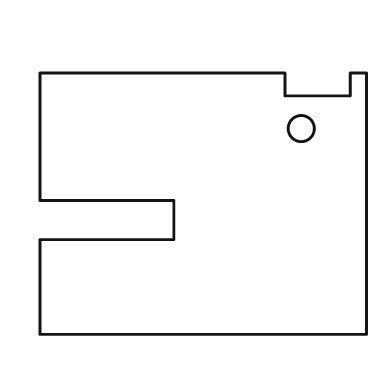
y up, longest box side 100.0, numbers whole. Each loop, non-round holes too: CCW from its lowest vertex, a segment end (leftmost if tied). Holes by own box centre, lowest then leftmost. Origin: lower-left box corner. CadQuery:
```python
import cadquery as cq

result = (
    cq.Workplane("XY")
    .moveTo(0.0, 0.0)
    .lineTo(100.0, 0.0)
    .lineTo(100.0, 80.0)
    .lineTo(95.0, 80.0)
    .lineTo(95.0, 73.0)
    .lineTo(75.0, 73.0)
    .lineTo(75.0, 80.0)
    .lineTo(0.0, 80.0)
    .lineTo(0.0, 41.0)
    .lineTo(41.0, 41.0)
    .lineTo(41.0, 29.0)
    .lineTo(0.0, 29.0)
    .close()
    .moveTo(80.0, 63.0)
    .circle(4.0)
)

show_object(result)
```